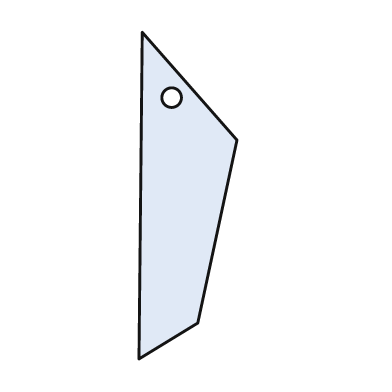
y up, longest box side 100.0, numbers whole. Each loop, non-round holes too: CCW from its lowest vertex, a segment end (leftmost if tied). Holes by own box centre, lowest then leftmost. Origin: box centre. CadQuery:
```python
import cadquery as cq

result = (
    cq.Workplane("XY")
    .moveTo(-15.0, -50.0)
    .lineTo(3.0, -39.0)
    .lineTo(15.0, 17.0)
    .lineTo(-14.0, 50.0)
    .close()
    .moveTo(-5.0, 30.0)
    .circle(3.0)
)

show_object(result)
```